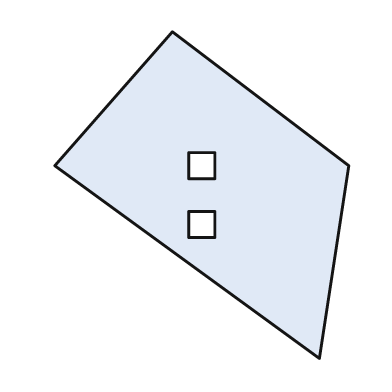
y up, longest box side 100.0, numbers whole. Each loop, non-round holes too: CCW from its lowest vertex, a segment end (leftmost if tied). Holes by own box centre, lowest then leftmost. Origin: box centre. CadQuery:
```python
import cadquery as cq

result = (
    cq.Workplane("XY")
    .moveTo(36.0, -50.0)
    .lineTo(45.0, 9.0)
    .lineTo(-9.0, 50.0)
    .lineTo(-45.0, 9.0)
    .close()
    .moveTo(-4.0, -13.0)
    .lineTo(4.0, -13.0)
    .lineTo(4.0, -5.0)
    .lineTo(-4.0, -5.0)
    .close()
    .moveTo(-4.0, 5.0)
    .lineTo(4.0, 5.0)
    .lineTo(4.0, 13.0)
    .lineTo(-4.0, 13.0)
    .close()
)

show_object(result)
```